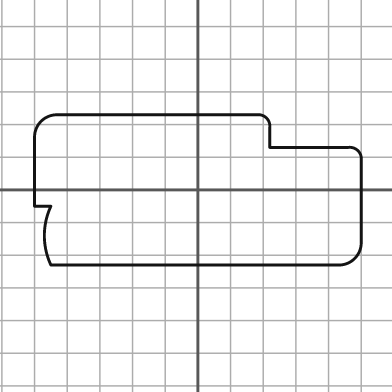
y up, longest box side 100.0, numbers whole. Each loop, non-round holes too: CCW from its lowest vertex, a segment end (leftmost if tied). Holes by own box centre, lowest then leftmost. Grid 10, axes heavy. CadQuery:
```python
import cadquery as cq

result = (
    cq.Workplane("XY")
    .moveTo(-45.0, -23.0)
    .lineTo(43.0, -23.0)
    .threePointArc((48.0, -21.0), (50.0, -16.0))
    .lineTo(50.0, 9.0)
    .threePointArc((49.0, 12.0), (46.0, 13.0))
    .lineTo(22.0, 13.0)
    .lineTo(22.0, 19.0)
    .threePointArc((21.0, 22.0), (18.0, 23.0))
    .lineTo(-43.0, 23.0)
    .threePointArc((-48.0, 21.0), (-50.0, 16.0))
    .lineTo(-50.0, -5.0)
    .lineTo(-45.0, -5.0)
    .threePointArc((-47.0, -14.0), (-45.0, -23.0))
    .close()
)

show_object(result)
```